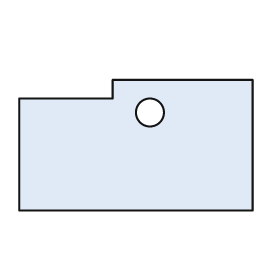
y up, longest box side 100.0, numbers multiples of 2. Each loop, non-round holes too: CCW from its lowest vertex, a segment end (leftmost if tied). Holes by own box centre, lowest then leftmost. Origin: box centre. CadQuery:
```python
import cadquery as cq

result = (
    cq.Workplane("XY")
    .moveTo(-50.0, -28.0)
    .lineTo(50.0, -28.0)
    .lineTo(50.0, 28.0)
    .lineTo(-10.0, 28.0)
    .lineTo(-10.0, 20.0)
    .lineTo(-50.0, 20.0)
    .close()
    .moveTo(6.0, 14.0)
    .circle(6.0)
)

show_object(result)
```